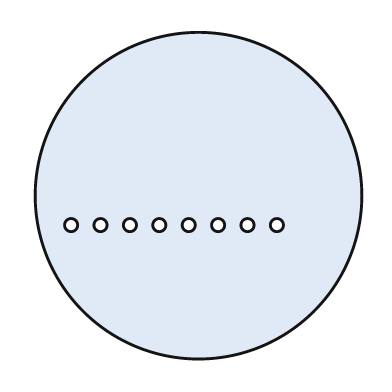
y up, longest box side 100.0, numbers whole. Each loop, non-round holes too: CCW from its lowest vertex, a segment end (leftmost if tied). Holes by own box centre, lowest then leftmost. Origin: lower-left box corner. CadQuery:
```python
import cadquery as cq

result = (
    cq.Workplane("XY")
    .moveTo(50.0, 50.0)
    .circle(50.0)
    .moveTo(11.0, 41.0)
    .circle(2.0)
    .moveTo(20.0, 41.0)
    .circle(2.0)
    .moveTo(29.0, 41.0)
    .circle(2.0)
    .moveTo(38.0, 41.0)
    .circle(2.0)
    .moveTo(47.0, 41.0)
    .circle(2.0)
    .moveTo(56.0, 41.0)
    .circle(2.0)
    .moveTo(65.0, 41.0)
    .circle(2.0)
    .moveTo(74.0, 41.0)
    .circle(2.0)
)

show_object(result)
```